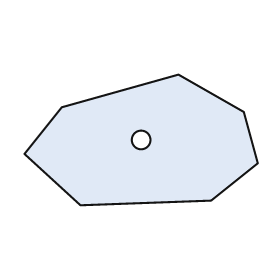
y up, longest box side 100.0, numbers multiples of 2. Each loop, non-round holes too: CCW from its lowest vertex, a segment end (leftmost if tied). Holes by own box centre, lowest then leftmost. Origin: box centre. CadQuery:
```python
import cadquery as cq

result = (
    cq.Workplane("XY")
    .moveTo(-26.0, -28.0)
    .lineTo(30.0, -26.0)
    .lineTo(50.0, -10.0)
    .lineTo(44.0, 12.0)
    .lineTo(16.0, 28.0)
    .lineTo(-34.0, 14.0)
    .lineTo(-50.0, -6.0)
    .close()
    .moveTo(0.0, 0.0)
    .circle(4.0)
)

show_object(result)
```